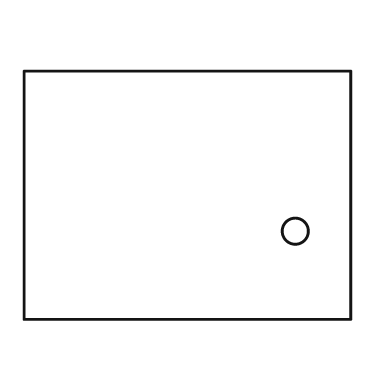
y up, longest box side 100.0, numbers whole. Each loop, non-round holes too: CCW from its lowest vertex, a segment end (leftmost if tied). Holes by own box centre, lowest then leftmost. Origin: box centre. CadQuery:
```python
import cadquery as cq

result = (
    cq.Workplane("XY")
    .moveTo(-50.0, -38.0)
    .lineTo(50.0, -38.0)
    .lineTo(50.0, 38.0)
    .lineTo(-50.0, 38.0)
    .close()
    .moveTo(33.0, -11.0)
    .circle(4.0)
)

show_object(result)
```